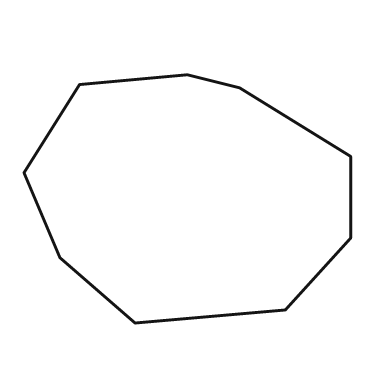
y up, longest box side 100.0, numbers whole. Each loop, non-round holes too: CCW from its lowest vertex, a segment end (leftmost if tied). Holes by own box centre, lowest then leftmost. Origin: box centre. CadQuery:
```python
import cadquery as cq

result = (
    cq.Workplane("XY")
    .moveTo(-16.0, -38.0)
    .lineTo(30.0, -34.0)
    .lineTo(50.0, -12.0)
    .lineTo(50.0, 13.0)
    .lineTo(16.0, 34.0)
    .lineTo(0.0, 38.0)
    .lineTo(-33.0, 35.0)
    .lineTo(-50.0, 8.0)
    .lineTo(-39.0, -18.0)
    .close()
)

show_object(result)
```